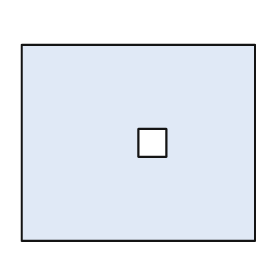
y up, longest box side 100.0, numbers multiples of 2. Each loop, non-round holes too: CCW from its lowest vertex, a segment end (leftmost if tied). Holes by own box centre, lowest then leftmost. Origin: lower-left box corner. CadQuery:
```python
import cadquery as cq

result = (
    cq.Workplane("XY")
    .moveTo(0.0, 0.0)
    .lineTo(100.0, 0.0)
    .lineTo(100.0, 84.0)
    .lineTo(0.0, 84.0)
    .close()
    .moveTo(50.0, 36.0)
    .lineTo(62.0, 36.0)
    .lineTo(62.0, 48.0)
    .lineTo(50.0, 48.0)
    .close()
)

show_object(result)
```